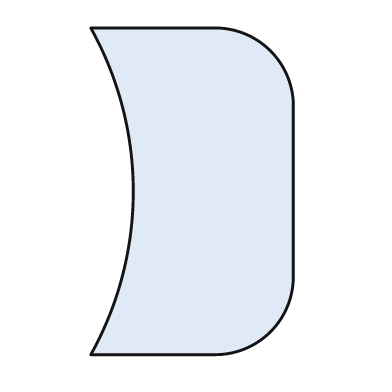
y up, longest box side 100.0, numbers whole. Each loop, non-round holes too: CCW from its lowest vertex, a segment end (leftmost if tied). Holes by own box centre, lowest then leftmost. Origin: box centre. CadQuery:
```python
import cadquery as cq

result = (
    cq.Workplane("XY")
    .moveTo(-31.0, -50.0)
    .lineTo(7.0, -50.0)
    .threePointArc((24.0, -43.0), (31.0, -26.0))
    .lineTo(31.0, 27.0)
    .threePointArc((24.0, 43.0), (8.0, 50.0))
    .lineTo(-31.0, 50.0)
    .threePointArc((-18.0, 0.0), (-31.0, -50.0))
    .close()
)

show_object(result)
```